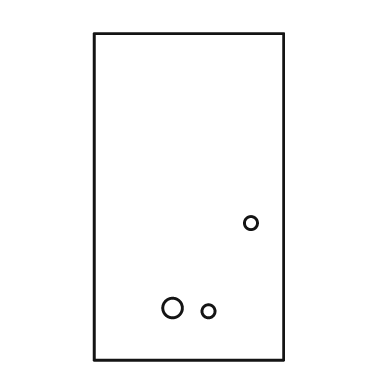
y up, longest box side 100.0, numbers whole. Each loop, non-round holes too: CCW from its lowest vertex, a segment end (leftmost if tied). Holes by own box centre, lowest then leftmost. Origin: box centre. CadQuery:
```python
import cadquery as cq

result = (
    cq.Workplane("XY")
    .moveTo(-29.0, -50.0)
    .lineTo(29.0, -50.0)
    .lineTo(29.0, 50.0)
    .lineTo(-29.0, 50.0)
    .close()
    .moveTo(6.0, -35.0)
    .circle(2.0)
    .moveTo(-5.0, -34.0)
    .circle(3.0)
    .moveTo(19.0, -8.0)
    .circle(2.0)
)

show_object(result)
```